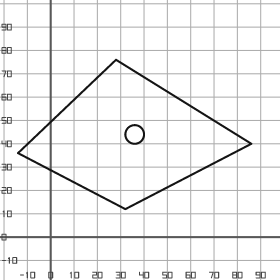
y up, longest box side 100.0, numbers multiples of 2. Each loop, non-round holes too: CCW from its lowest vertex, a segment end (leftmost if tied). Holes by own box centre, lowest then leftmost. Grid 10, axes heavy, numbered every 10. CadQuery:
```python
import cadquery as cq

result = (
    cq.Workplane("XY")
    .moveTo(32.0, 12.0)
    .lineTo(86.0, 40.0)
    .lineTo(28.0, 76.0)
    .lineTo(-14.0, 36.0)
    .close()
    .moveTo(36.0, 44.0)
    .circle(4.0)
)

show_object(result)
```